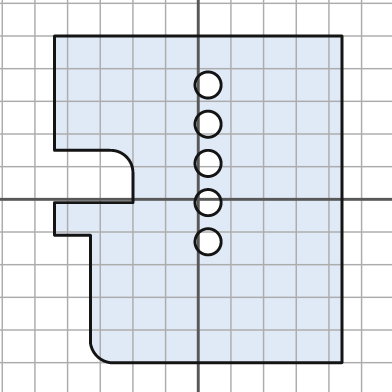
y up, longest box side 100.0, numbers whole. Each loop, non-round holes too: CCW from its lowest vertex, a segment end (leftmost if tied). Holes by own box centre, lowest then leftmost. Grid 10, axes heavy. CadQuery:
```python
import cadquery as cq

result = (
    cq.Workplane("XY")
    .moveTo(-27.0, -50.0)
    .lineTo(44.0, -50.0)
    .lineTo(44.0, 50.0)
    .lineTo(-44.0, 50.0)
    .lineTo(-44.0, 15.0)
    .lineTo(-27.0, 15.0)
    .threePointArc((-22.0, 13.0), (-20.0, 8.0))
    .lineTo(-20.0, -1.0)
    .lineTo(-44.0, -1.0)
    .lineTo(-44.0, -11.0)
    .lineTo(-33.0, -11.0)
    .lineTo(-33.0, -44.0)
    .threePointArc((-31.0, -48.0), (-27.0, -50.0))
    .close()
    .moveTo(3.0, -13.0)
    .circle(4.0)
    .moveTo(3.0, -1.0)
    .circle(4.0)
    .moveTo(3.0, 11.0)
    .circle(4.0)
    .moveTo(3.0, 23.0)
    .circle(4.0)
    .moveTo(3.0, 35.0)
    .circle(4.0)
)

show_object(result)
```